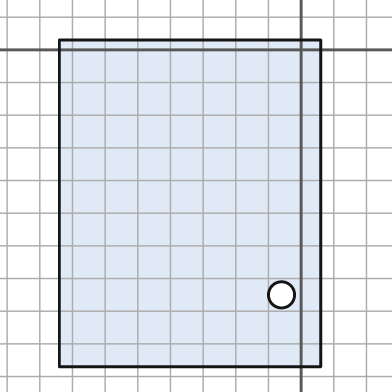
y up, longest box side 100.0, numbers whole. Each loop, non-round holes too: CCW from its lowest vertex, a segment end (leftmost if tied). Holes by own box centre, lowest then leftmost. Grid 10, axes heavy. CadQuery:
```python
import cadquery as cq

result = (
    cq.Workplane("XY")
    .moveTo(-74.0, -97.0)
    .lineTo(6.0, -97.0)
    .lineTo(6.0, 3.0)
    .lineTo(-74.0, 3.0)
    .close()
    .moveTo(-6.0, -75.0)
    .circle(4.0)
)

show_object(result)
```